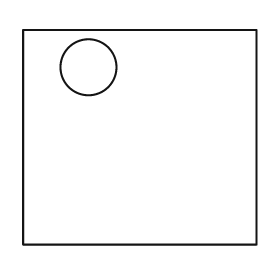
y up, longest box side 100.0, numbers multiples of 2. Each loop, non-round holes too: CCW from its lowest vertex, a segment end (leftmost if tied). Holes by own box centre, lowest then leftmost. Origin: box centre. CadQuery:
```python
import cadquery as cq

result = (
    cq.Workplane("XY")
    .moveTo(-50.0, -46.0)
    .lineTo(50.0, -46.0)
    .lineTo(50.0, 46.0)
    .lineTo(-50.0, 46.0)
    .close()
    .moveTo(-22.0, 30.0)
    .circle(12.0)
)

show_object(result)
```